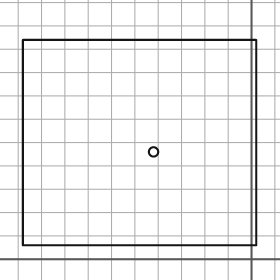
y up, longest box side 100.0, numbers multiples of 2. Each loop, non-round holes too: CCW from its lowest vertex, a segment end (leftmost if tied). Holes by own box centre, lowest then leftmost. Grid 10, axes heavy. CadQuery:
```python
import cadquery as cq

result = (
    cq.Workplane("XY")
    .moveTo(-98.0, 6.0)
    .lineTo(2.0, 6.0)
    .lineTo(2.0, 94.0)
    .lineTo(-98.0, 94.0)
    .close()
    .moveTo(-42.0, 46.0)
    .circle(2.0)
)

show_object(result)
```